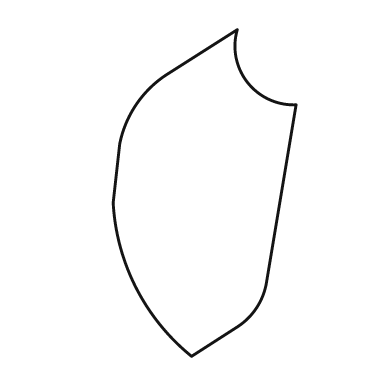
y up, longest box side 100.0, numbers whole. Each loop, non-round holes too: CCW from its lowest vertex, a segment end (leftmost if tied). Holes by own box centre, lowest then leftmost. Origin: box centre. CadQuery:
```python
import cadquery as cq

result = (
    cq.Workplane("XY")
    .moveTo(-4.0, -50.0)
    .lineTo(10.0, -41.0)
    .threePointArc((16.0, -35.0), (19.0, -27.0))
    .lineTo(28.0, 27.0)
    .threePointArc((13.0, 34.0), (10.0, 50.0))
    .lineTo(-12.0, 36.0)
    .threePointArc((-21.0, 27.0), (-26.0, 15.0))
    .lineTo(-28.0, -3.0)
    .threePointArc((-21.0, -29.0), (-4.0, -50.0))
    .close()
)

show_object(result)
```